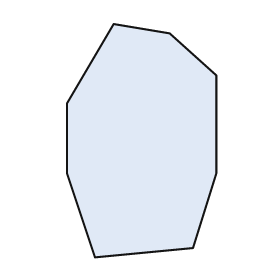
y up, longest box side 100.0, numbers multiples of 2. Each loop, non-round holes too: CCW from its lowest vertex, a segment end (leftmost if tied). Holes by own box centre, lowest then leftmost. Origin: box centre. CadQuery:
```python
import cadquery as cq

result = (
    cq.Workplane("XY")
    .moveTo(-20.0, -50.0)
    .lineTo(22.0, -46.0)
    .lineTo(32.0, -14.0)
    .lineTo(32.0, 28.0)
    .lineTo(12.0, 46.0)
    .lineTo(-12.0, 50.0)
    .lineTo(-32.0, 16.0)
    .lineTo(-32.0, -14.0)
    .close()
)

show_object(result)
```